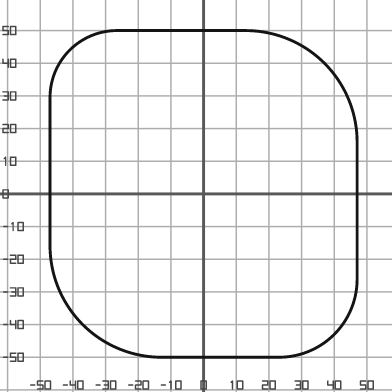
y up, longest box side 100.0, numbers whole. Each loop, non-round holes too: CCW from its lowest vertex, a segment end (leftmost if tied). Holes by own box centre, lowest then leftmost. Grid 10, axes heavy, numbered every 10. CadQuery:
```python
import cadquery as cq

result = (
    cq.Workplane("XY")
    .moveTo(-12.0, -50.0)
    .lineTo(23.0, -50.0)
    .threePointArc((40.0, -43.0), (47.0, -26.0))
    .lineTo(47.0, 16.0)
    .threePointArc((37.0, 40.0), (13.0, 50.0))
    .lineTo(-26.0, 50.0)
    .threePointArc((-41.0, 44.0), (-47.0, 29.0))
    .lineTo(-47.0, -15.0)
    .threePointArc((-37.0, -40.0), (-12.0, -50.0))
    .close()
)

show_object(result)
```